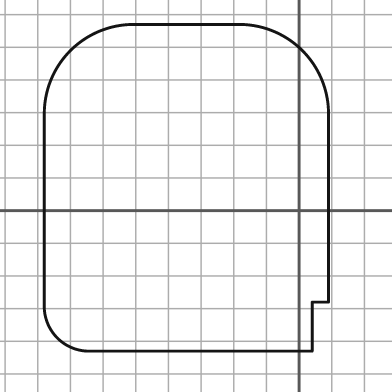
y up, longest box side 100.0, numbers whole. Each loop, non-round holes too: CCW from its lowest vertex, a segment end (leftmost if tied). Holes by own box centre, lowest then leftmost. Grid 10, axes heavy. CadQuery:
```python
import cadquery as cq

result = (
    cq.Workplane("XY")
    .moveTo(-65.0, -43.0)
    .lineTo(4.0, -43.0)
    .lineTo(4.0, -28.0)
    .lineTo(9.0, -28.0)
    .lineTo(9.0, 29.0)
    .threePointArc((1.0, 49.0), (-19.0, 57.0))
    .lineTo(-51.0, 57.0)
    .threePointArc((-70.0, 49.0), (-78.0, 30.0))
    .lineTo(-78.0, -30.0)
    .threePointArc((-74.0, -39.0), (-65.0, -43.0))
    .close()
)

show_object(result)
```